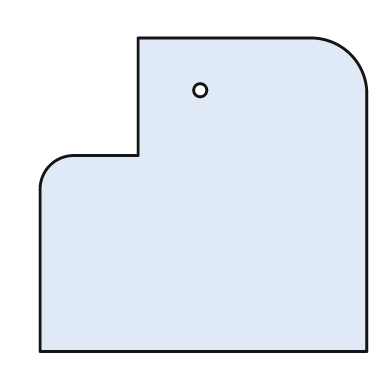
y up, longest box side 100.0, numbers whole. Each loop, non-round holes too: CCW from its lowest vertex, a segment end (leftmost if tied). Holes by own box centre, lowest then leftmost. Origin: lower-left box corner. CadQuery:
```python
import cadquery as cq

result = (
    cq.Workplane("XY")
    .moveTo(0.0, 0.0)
    .lineTo(100.0, 0.0)
    .lineTo(100.0, 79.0)
    .threePointArc((95.0, 91.0), (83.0, 96.0))
    .lineTo(30.0, 96.0)
    .lineTo(30.0, 60.0)
    .lineTo(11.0, 60.0)
    .threePointArc((3.0, 57.0), (0.0, 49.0))
    .close()
    .moveTo(49.0, 80.0)
    .circle(2.0)
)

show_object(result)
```